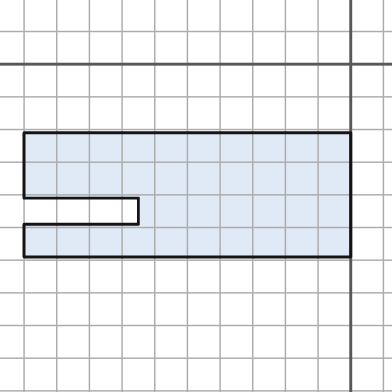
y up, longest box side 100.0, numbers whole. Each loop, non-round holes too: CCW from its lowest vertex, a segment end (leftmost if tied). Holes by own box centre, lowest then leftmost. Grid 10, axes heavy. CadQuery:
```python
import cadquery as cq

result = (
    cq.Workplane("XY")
    .moveTo(-100.0, -59.0)
    .lineTo(0.0, -59.0)
    .lineTo(0.0, -21.0)
    .lineTo(-100.0, -21.0)
    .lineTo(-100.0, -41.0)
    .lineTo(-65.0, -41.0)
    .lineTo(-65.0, -49.0)
    .lineTo(-100.0, -49.0)
    .close()
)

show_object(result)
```